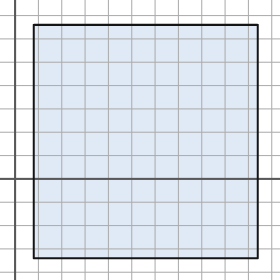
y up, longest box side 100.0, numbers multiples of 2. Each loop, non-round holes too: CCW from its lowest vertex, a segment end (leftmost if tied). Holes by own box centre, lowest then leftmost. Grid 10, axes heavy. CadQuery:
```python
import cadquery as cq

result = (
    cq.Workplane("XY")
    .moveTo(8.0, -34.0)
    .lineTo(104.0, -34.0)
    .lineTo(104.0, 66.0)
    .lineTo(8.0, 66.0)
    .close()
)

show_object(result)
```